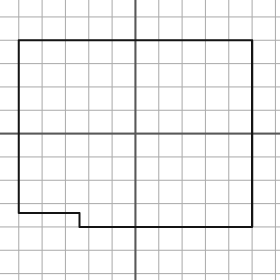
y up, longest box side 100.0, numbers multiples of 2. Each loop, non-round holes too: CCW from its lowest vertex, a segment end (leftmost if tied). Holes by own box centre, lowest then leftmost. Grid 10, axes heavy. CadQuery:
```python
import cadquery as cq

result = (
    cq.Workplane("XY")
    .moveTo(-24.0, -40.0)
    .lineTo(50.0, -40.0)
    .lineTo(50.0, 40.0)
    .lineTo(-50.0, 40.0)
    .lineTo(-50.0, -34.0)
    .lineTo(-24.0, -34.0)
    .close()
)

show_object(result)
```